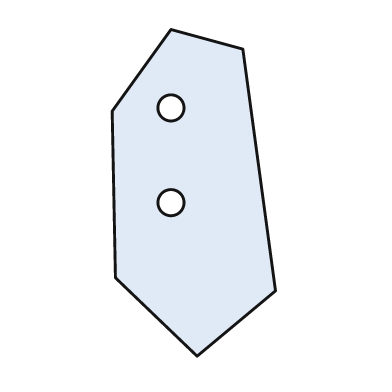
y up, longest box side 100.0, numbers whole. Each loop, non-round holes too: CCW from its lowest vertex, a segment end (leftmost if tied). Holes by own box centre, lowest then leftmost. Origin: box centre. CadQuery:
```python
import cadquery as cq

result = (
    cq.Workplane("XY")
    .moveTo(1.0, -50.0)
    .lineTo(25.0, -30.0)
    .lineTo(15.0, 44.0)
    .lineTo(-7.0, 50.0)
    .lineTo(-25.0, 25.0)
    .lineTo(-24.0, -26.0)
    .close()
    .moveTo(-7.0, -3.0)
    .circle(4.0)
    .moveTo(-7.0, 26.0)
    .circle(4.0)
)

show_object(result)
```